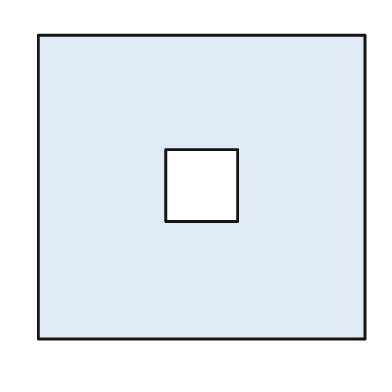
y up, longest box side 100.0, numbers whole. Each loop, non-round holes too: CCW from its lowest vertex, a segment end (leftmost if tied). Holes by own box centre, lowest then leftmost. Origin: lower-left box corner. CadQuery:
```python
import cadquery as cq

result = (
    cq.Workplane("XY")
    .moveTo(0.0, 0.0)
    .lineTo(100.0, 0.0)
    .lineTo(100.0, 93.0)
    .lineTo(0.0, 93.0)
    .close()
    .moveTo(39.0, 36.0)
    .lineTo(61.0, 36.0)
    .lineTo(61.0, 58.0)
    .lineTo(39.0, 58.0)
    .close()
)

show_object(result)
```